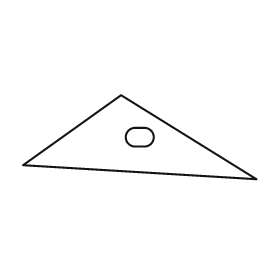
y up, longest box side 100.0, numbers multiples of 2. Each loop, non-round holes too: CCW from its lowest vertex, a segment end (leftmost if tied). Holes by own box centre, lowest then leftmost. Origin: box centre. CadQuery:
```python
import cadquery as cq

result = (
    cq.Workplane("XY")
    .moveTo(50.0, -18.0)
    .lineTo(-8.0, 18.0)
    .lineTo(-50.0, -12.0)
    .close()
    .moveTo(-2.0, -4.0)
    .lineTo(2.0, -4.0)
    .threePointArc((6.0, 0.0), (2.0, 4.0))
    .lineTo(-2.0, 4.0)
    .threePointArc((-6.0, 0.0), (-2.0, -4.0))
    .close()
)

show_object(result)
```